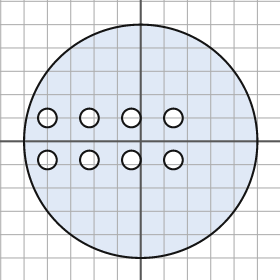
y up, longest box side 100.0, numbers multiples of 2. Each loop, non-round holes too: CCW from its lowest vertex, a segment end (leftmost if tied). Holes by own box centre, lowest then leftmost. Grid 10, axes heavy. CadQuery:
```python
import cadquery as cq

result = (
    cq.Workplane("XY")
    .moveTo(0.0, 0.0)
    .circle(50.0)
    .moveTo(-40.0, -8.0)
    .circle(4.0)
    .moveTo(-22.0, -8.0)
    .circle(4.0)
    .moveTo(-4.0, -8.0)
    .circle(4.0)
    .moveTo(14.0, -8.0)
    .circle(4.0)
    .moveTo(-40.0, 10.0)
    .circle(4.0)
    .moveTo(-22.0, 10.0)
    .circle(4.0)
    .moveTo(-4.0, 10.0)
    .circle(4.0)
    .moveTo(14.0, 10.0)
    .circle(4.0)
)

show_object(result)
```